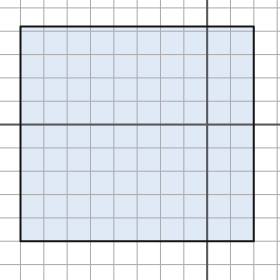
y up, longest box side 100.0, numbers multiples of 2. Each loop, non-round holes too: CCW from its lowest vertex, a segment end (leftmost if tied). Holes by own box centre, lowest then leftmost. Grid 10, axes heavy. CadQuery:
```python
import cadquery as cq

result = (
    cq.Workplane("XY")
    .moveTo(-80.0, -50.0)
    .lineTo(20.0, -50.0)
    .lineTo(20.0, 42.0)
    .lineTo(-80.0, 42.0)
    .close()
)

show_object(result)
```